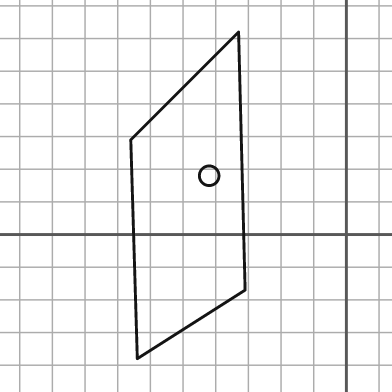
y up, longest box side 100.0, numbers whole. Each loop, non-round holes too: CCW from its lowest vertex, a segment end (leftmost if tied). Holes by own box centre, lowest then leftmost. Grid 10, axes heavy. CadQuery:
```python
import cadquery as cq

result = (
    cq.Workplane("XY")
    .moveTo(-64.0, -38.0)
    .lineTo(-31.0, -17.0)
    .lineTo(-33.0, 62.0)
    .lineTo(-66.0, 29.0)
    .close()
    .moveTo(-42.0, 18.0)
    .circle(3.0)
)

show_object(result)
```